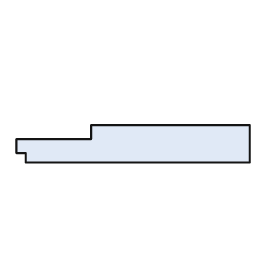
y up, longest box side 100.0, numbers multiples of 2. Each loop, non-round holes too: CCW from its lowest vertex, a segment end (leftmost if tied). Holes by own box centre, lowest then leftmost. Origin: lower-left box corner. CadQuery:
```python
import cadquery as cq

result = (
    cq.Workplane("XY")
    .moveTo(4.0, 0.0)
    .lineTo(100.0, 0.0)
    .lineTo(100.0, 16.0)
    .lineTo(32.0, 16.0)
    .lineTo(32.0, 10.0)
    .lineTo(0.0, 10.0)
    .lineTo(0.0, 4.0)
    .lineTo(4.0, 4.0)
    .close()
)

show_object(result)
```